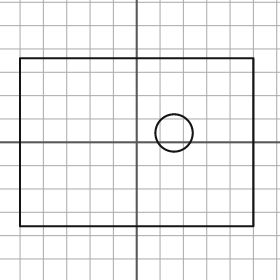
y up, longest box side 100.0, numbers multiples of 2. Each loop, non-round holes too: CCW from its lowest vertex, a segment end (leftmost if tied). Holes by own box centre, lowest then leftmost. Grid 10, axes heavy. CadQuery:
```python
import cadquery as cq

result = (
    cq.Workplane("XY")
    .moveTo(-50.0, -36.0)
    .lineTo(50.0, -36.0)
    .lineTo(50.0, 36.0)
    .lineTo(-50.0, 36.0)
    .close()
    .moveTo(16.0, 4.0)
    .circle(8.0)
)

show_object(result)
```